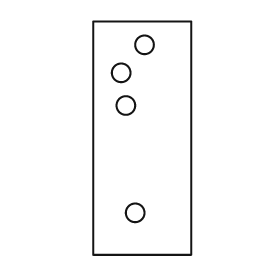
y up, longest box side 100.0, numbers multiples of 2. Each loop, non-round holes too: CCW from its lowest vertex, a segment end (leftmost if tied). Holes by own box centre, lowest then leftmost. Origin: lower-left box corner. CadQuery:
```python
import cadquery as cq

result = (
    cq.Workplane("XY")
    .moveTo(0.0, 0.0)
    .lineTo(42.0, 0.0)
    .lineTo(42.0, 100.0)
    .lineTo(0.0, 100.0)
    .close()
    .moveTo(18.0, 18.0)
    .circle(4.0)
    .moveTo(14.0, 64.0)
    .circle(4.0)
    .moveTo(12.0, 78.0)
    .circle(4.0)
    .moveTo(22.0, 90.0)
    .circle(4.0)
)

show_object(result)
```